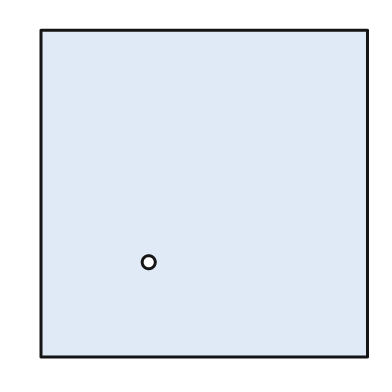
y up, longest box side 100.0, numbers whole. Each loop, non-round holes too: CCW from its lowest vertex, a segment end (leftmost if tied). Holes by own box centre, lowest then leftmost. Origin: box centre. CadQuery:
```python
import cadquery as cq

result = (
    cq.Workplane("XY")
    .moveTo(-50.0, -50.0)
    .lineTo(50.0, -50.0)
    .lineTo(50.0, 50.0)
    .lineTo(-50.0, 50.0)
    .close()
    .moveTo(-17.0, -21.0)
    .circle(2.0)
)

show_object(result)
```